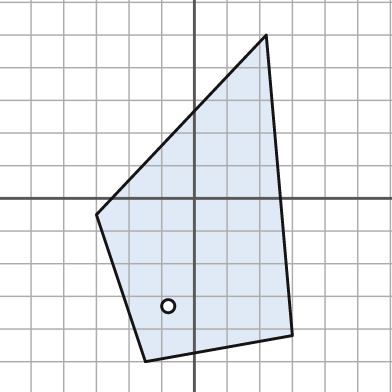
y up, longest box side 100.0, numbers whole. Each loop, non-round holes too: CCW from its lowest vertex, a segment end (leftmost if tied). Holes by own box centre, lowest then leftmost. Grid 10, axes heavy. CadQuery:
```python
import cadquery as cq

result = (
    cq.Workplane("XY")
    .moveTo(-15.0, -50.0)
    .lineTo(30.0, -42.0)
    .lineTo(22.0, 50.0)
    .lineTo(-30.0, -5.0)
    .close()
    .moveTo(-8.0, -33.0)
    .circle(2.0)
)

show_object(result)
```